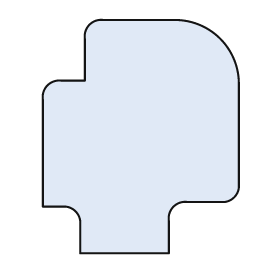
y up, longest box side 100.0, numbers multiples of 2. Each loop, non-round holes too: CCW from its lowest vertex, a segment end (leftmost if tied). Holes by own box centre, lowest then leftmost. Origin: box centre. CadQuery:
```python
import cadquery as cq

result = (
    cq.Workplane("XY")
    .moveTo(-26.0, -50.0)
    .lineTo(12.0, -50.0)
    .lineTo(12.0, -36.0)
    .threePointArc((14.0, -30.0), (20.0, -28.0))
    .lineTo(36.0, -28.0)
    .threePointArc((40.0, -26.0), (42.0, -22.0))
    .lineTo(42.0, 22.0)
    .threePointArc((34.0, 42.0), (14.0, 50.0))
    .lineTo(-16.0, 50.0)
    .threePointArc((-22.0, 48.0), (-24.0, 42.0))
    .lineTo(-24.0, 24.0)
    .lineTo(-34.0, 24.0)
    .threePointArc((-40.0, 22.0), (-42.0, 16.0))
    .lineTo(-42.0, -30.0)
    .lineTo(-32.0, -30.0)
    .threePointArc((-28.0, -32.0), (-26.0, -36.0))
    .close()
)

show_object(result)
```